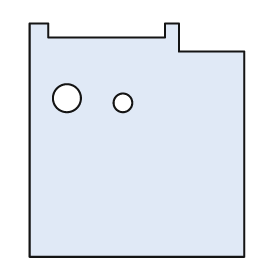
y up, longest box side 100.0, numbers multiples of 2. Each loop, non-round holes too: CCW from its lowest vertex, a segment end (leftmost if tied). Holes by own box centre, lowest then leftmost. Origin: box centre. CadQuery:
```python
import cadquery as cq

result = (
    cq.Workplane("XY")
    .moveTo(-46.0, -50.0)
    .lineTo(46.0, -50.0)
    .lineTo(46.0, 38.0)
    .lineTo(18.0, 38.0)
    .lineTo(18.0, 50.0)
    .lineTo(12.0, 50.0)
    .lineTo(12.0, 44.0)
    .lineTo(-38.0, 44.0)
    .lineTo(-38.0, 50.0)
    .lineTo(-46.0, 50.0)
    .close()
    .moveTo(-6.0, 16.0)
    .circle(4.0)
    .moveTo(-30.0, 18.0)
    .circle(6.0)
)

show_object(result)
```